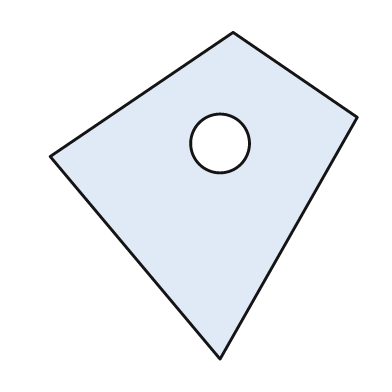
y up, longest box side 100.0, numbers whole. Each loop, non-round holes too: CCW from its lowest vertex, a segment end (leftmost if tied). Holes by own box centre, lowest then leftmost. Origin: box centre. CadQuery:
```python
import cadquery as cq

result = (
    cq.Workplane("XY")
    .moveTo(5.0, -50.0)
    .lineTo(47.0, 24.0)
    .lineTo(9.0, 50.0)
    .lineTo(-47.0, 12.0)
    .close()
    .moveTo(5.0, 16.0)
    .circle(9.0)
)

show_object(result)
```